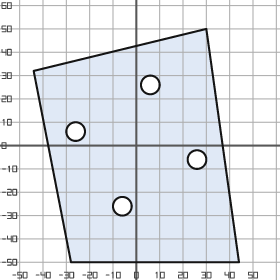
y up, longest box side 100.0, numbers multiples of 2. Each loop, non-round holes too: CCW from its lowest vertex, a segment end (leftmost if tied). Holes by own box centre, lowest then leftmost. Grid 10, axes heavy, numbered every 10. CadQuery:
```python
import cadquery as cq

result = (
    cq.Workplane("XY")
    .moveTo(-28.0, -50.0)
    .lineTo(44.0, -50.0)
    .lineTo(30.0, 50.0)
    .lineTo(-44.0, 32.0)
    .close()
    .moveTo(-6.0, -26.0)
    .circle(4.0)
    .moveTo(26.0, -6.0)
    .circle(4.0)
    .moveTo(-26.0, 6.0)
    .circle(4.0)
    .moveTo(6.0, 26.0)
    .circle(4.0)
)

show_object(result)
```